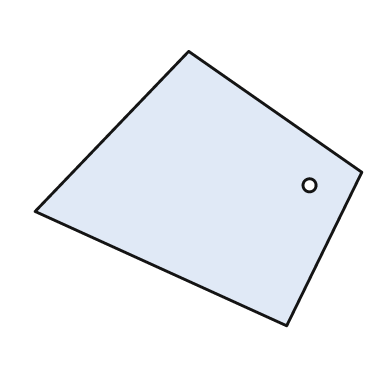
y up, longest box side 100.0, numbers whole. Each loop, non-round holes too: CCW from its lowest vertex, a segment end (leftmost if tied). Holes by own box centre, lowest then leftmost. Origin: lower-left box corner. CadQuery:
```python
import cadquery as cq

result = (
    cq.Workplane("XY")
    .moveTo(77.0, 0.0)
    .lineTo(100.0, 47.0)
    .lineTo(47.0, 84.0)
    .lineTo(0.0, 35.0)
    .close()
    .moveTo(84.0, 43.0)
    .circle(2.0)
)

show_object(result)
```